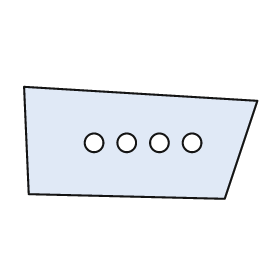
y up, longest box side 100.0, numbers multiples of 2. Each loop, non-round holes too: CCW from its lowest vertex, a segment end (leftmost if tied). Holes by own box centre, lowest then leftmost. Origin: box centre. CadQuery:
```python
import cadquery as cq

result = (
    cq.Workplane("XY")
    .moveTo(36.0, -24.0)
    .lineTo(50.0, 18.0)
    .lineTo(-50.0, 24.0)
    .lineTo(-48.0, -22.0)
    .close()
    .moveTo(-20.0, 0.0)
    .circle(4.0)
    .moveTo(-6.0, 0.0)
    .circle(4.0)
    .moveTo(8.0, 0.0)
    .circle(4.0)
    .moveTo(22.0, 0.0)
    .circle(4.0)
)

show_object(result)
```